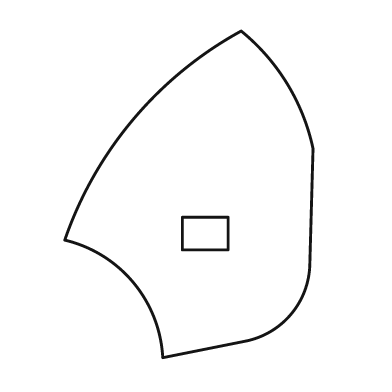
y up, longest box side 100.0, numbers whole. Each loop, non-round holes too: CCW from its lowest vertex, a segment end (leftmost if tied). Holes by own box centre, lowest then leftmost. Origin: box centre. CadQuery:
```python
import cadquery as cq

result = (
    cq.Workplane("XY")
    .moveTo(-8.0, -50.0)
    .lineTo(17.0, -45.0)
    .threePointArc((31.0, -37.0), (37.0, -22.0))
    .lineTo(38.0, 14.0)
    .threePointArc((30.0, 34.0), (16.0, 50.0))
    .threePointArc((-17.0, 23.0), (-38.0, -14.0))
    .threePointArc((-17.0, -27.0), (-8.0, -50.0))
    .close()
    .moveTo(-2.0, -17.0)
    .lineTo(12.0, -17.0)
    .lineTo(12.0, -7.0)
    .lineTo(-2.0, -7.0)
    .close()
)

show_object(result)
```